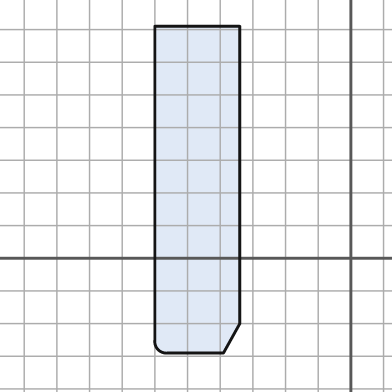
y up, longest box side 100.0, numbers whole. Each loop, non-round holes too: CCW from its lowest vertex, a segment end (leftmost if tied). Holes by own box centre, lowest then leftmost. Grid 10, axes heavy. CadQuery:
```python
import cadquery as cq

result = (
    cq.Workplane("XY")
    .moveTo(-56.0, -29.0)
    .lineTo(-39.0, -29.0)
    .lineTo(-34.0, -20.0)
    .lineTo(-34.0, 71.0)
    .lineTo(-60.0, 71.0)
    .lineTo(-60.0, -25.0)
    .threePointArc((-59.0, -28.0), (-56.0, -29.0))
    .close()
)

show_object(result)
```